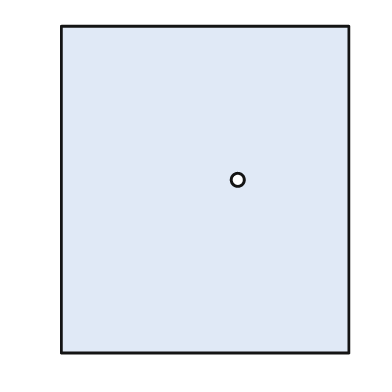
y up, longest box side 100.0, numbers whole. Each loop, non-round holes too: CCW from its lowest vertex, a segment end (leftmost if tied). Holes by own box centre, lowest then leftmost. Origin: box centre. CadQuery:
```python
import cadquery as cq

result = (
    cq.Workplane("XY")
    .moveTo(-44.0, -50.0)
    .lineTo(44.0, -50.0)
    .lineTo(44.0, 50.0)
    .lineTo(-44.0, 50.0)
    .close()
    .moveTo(10.0, 3.0)
    .circle(2.0)
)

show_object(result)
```